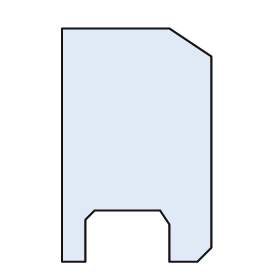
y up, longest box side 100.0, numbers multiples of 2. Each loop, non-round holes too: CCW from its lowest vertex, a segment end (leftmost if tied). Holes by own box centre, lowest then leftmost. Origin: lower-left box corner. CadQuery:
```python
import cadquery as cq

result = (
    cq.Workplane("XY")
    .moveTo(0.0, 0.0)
    .lineTo(10.0, 0.0)
    .lineTo(10.0, 18.0)
    .lineTo(14.0, 22.0)
    .lineTo(42.0, 22.0)
    .lineTo(46.0, 16.0)
    .lineTo(46.0, 0.0)
    .lineTo(58.0, 0.0)
    .lineTo(64.0, 6.0)
    .lineTo(64.0, 88.0)
    .lineTo(46.0, 100.0)
    .lineTo(0.0, 100.0)
    .close()
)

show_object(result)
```